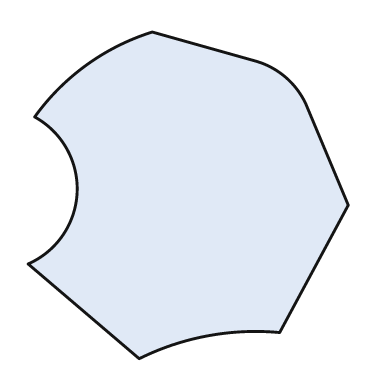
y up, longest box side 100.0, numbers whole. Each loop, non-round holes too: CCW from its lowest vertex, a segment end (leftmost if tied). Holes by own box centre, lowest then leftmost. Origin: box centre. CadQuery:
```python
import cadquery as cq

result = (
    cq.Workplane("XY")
    .moveTo(-15.0, -50.0)
    .threePointArc((6.0, -43.0), (28.0, -42.0))
    .lineTo(49.0, -3.0)
    .lineTo(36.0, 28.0)
    .threePointArc((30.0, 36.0), (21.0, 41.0))
    .lineTo(-11.0, 50.0)
    .threePointArc((-31.0, 40.0), (-47.0, 24.0))
    .threePointArc((-34.0, 1.0), (-49.0, -21.0))
    .close()
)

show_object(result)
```